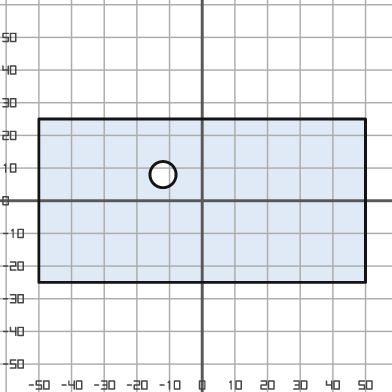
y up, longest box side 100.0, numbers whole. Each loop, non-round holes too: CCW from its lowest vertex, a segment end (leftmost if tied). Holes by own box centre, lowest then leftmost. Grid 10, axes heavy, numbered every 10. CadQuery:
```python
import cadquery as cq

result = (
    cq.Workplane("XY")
    .moveTo(-50.0, -25.0)
    .lineTo(50.0, -25.0)
    .lineTo(50.0, 25.0)
    .lineTo(-50.0, 25.0)
    .close()
    .moveTo(-12.0, 8.0)
    .circle(4.0)
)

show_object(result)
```